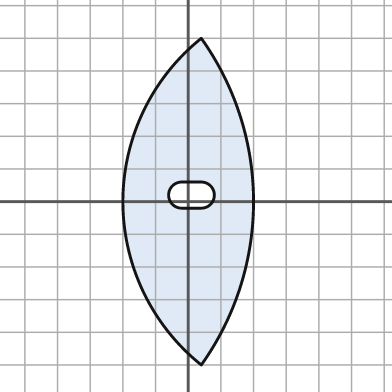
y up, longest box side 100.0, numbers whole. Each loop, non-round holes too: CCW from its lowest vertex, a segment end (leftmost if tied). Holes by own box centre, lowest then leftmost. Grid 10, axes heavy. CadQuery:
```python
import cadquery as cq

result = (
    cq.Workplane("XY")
    .moveTo(4.0, -50.0)
    .threePointArc((20.0, 0.0), (4.0, 50.0))
    .threePointArc((-20.0, 0.0), (4.0, -50.0))
    .close()
    .moveTo(-2.0, -2.0)
    .lineTo(4.0, -2.0)
    .threePointArc((8.0, 2.0), (4.0, 6.0))
    .lineTo(-2.0, 6.0)
    .threePointArc((-6.0, 2.0), (-2.0, -2.0))
    .close()
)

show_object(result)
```